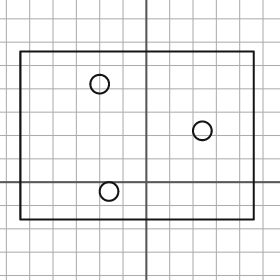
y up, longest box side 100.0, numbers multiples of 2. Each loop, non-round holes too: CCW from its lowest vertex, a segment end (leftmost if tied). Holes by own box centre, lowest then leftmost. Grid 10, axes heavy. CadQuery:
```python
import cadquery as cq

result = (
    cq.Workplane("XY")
    .moveTo(-54.0, -16.0)
    .lineTo(46.0, -16.0)
    .lineTo(46.0, 56.0)
    .lineTo(-54.0, 56.0)
    .close()
    .moveTo(-16.0, -4.0)
    .circle(4.0)
    .moveTo(24.0, 22.0)
    .circle(4.0)
    .moveTo(-20.0, 42.0)
    .circle(4.0)
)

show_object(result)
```